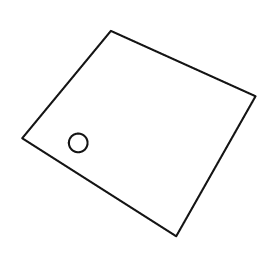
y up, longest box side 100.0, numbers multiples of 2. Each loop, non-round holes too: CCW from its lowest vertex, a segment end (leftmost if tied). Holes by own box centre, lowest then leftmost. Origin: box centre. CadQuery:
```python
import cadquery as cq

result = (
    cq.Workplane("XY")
    .moveTo(16.0, -44.0)
    .lineTo(50.0, 16.0)
    .lineTo(-12.0, 44.0)
    .lineTo(-50.0, -2.0)
    .close()
    .moveTo(-26.0, -4.0)
    .circle(4.0)
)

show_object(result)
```